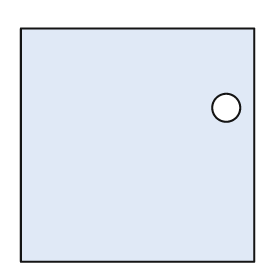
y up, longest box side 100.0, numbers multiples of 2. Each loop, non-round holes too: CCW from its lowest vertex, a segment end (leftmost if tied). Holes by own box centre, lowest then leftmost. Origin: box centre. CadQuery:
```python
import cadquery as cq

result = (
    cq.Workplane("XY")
    .moveTo(-50.0, -50.0)
    .lineTo(50.0, -50.0)
    .lineTo(50.0, 50.0)
    .lineTo(-50.0, 50.0)
    .close()
    .moveTo(38.0, 16.0)
    .circle(6.0)
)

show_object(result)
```